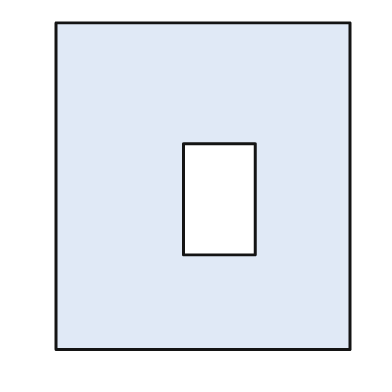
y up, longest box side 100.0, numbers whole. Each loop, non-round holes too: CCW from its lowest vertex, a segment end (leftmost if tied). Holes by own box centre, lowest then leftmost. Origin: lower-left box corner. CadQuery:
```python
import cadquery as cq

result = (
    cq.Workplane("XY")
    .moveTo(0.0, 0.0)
    .lineTo(90.0, 0.0)
    .lineTo(90.0, 100.0)
    .lineTo(0.0, 100.0)
    .close()
    .moveTo(39.0, 29.0)
    .lineTo(61.0, 29.0)
    .lineTo(61.0, 63.0)
    .lineTo(39.0, 63.0)
    .close()
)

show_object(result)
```